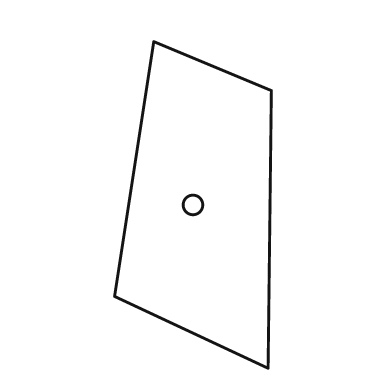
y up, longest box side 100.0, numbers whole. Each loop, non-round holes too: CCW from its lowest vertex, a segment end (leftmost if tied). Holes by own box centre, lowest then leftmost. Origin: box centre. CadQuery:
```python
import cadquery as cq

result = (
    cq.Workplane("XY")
    .moveTo(23.0, -50.0)
    .lineTo(24.0, 35.0)
    .lineTo(-12.0, 50.0)
    .lineTo(-24.0, -28.0)
    .close()
    .moveTo(0.0, 0.0)
    .circle(3.0)
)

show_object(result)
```